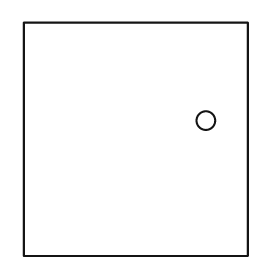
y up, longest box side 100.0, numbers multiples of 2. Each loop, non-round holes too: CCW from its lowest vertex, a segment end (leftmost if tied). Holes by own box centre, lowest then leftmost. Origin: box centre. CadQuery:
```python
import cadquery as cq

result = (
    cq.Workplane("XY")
    .moveTo(-48.0, -50.0)
    .lineTo(48.0, -50.0)
    .lineTo(48.0, 50.0)
    .lineTo(-48.0, 50.0)
    .close()
    .moveTo(30.0, 8.0)
    .circle(4.0)
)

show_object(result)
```